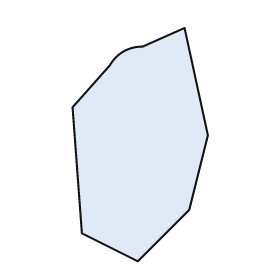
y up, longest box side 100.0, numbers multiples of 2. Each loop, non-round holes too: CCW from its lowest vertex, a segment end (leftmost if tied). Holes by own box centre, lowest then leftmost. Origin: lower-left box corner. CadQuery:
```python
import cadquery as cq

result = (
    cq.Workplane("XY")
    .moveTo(28.0, 0.0)
    .lineTo(50.0, 22.0)
    .lineTo(58.0, 54.0)
    .lineTo(48.0, 100.0)
    .lineTo(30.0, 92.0)
    .threePointArc((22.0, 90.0), (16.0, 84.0))
    .lineTo(0.0, 66.0)
    .lineTo(4.0, 12.0)
    .close()
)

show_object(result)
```